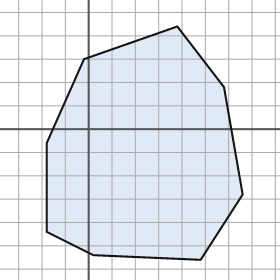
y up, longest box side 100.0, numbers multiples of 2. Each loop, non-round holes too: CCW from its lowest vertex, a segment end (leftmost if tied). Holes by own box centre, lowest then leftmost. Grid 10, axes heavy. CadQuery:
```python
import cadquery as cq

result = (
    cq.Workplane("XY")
    .moveTo(48.0, -56.0)
    .lineTo(66.0, -28.0)
    .lineTo(58.0, 18.0)
    .lineTo(38.0, 44.0)
    .lineTo(-2.0, 30.0)
    .lineTo(-18.0, -6.0)
    .lineTo(-18.0, -44.0)
    .lineTo(2.0, -54.0)
    .close()
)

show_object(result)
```